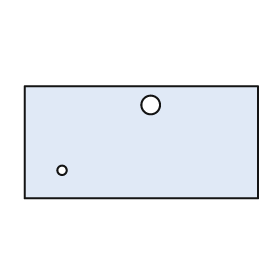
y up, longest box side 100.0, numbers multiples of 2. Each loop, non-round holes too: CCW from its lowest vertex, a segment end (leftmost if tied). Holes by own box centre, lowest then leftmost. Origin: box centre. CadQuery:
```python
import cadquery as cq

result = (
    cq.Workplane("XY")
    .moveTo(-50.0, -24.0)
    .lineTo(50.0, -24.0)
    .lineTo(50.0, 24.0)
    .lineTo(-50.0, 24.0)
    .close()
    .moveTo(-34.0, -12.0)
    .circle(2.0)
    .moveTo(4.0, 16.0)
    .circle(4.0)
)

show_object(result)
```